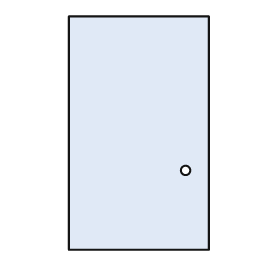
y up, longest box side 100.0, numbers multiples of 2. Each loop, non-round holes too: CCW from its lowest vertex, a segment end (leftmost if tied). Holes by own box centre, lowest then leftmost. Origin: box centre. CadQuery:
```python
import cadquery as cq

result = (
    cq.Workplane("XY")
    .moveTo(-30.0, -50.0)
    .lineTo(30.0, -50.0)
    .lineTo(30.0, 50.0)
    .lineTo(-30.0, 50.0)
    .close()
    .moveTo(20.0, -16.0)
    .circle(2.0)
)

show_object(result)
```